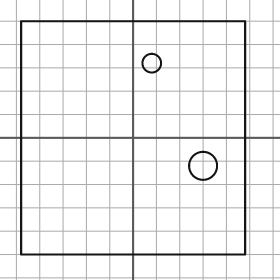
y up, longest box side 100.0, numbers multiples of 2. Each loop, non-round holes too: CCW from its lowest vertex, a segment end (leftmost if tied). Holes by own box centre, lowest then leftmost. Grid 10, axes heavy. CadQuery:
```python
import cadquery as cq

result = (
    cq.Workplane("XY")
    .moveTo(-48.0, -50.0)
    .lineTo(48.0, -50.0)
    .lineTo(48.0, 50.0)
    .lineTo(-48.0, 50.0)
    .close()
    .moveTo(30.0, -12.0)
    .circle(6.0)
    .moveTo(8.0, 32.0)
    .circle(4.0)
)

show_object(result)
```